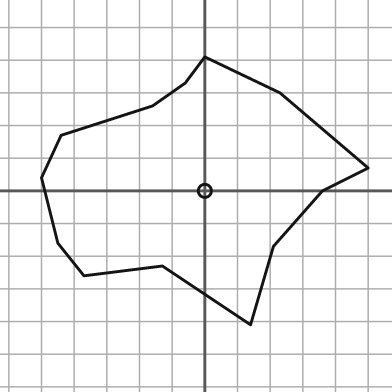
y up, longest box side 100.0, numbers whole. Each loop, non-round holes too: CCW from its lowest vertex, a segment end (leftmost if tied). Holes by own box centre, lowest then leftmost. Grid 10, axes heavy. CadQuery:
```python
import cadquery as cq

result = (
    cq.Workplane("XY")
    .moveTo(14.0, -41.0)
    .lineTo(21.0, -17.0)
    .lineTo(36.0, 0.0)
    .lineTo(50.0, 7.0)
    .lineTo(23.0, 30.0)
    .lineTo(0.0, 41.0)
    .lineTo(-6.0, 33.0)
    .lineTo(-16.0, 26.0)
    .lineTo(-44.0, 17.0)
    .lineTo(-50.0, 4.0)
    .lineTo(-45.0, -16.0)
    .lineTo(-37.0, -26.0)
    .lineTo(-13.0, -23.0)
    .close()
    .moveTo(0.0, 0.0)
    .circle(2.0)
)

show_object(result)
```